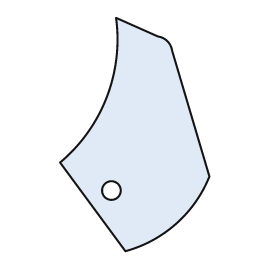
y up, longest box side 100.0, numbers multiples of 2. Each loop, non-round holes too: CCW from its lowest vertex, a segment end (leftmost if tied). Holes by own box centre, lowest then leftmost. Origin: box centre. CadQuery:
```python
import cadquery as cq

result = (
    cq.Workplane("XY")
    .moveTo(-4.0, -50.0)
    .threePointArc((18.0, -38.0), (32.0, -18.0))
    .lineTo(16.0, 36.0)
    .threePointArc((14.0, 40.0), (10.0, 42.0))
    .lineTo(-8.0, 50.0)
    .threePointArc((-12.0, 16.0), (-32.0, -12.0))
    .close()
    .moveTo(-10.0, -24.0)
    .circle(4.0)
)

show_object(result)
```